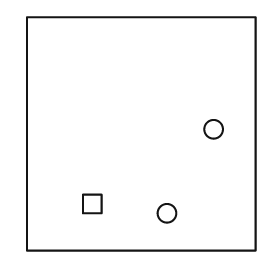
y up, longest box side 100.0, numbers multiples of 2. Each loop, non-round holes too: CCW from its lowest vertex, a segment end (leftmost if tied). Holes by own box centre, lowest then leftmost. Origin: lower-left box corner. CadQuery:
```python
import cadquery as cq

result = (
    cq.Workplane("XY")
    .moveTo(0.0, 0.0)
    .lineTo(98.0, 0.0)
    .lineTo(98.0, 100.0)
    .lineTo(0.0, 100.0)
    .close()
    .moveTo(60.0, 16.0)
    .circle(4.0)
    .moveTo(24.0, 16.0)
    .lineTo(32.0, 16.0)
    .lineTo(32.0, 24.0)
    .lineTo(24.0, 24.0)
    .close()
    .moveTo(80.0, 52.0)
    .circle(4.0)
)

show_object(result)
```